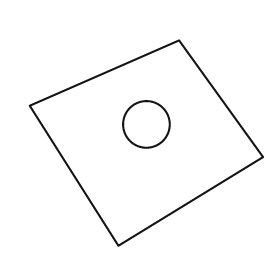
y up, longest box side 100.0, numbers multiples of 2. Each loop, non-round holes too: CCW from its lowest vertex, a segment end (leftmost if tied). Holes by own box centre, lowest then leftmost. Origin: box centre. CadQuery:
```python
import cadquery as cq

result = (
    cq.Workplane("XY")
    .moveTo(-12.0, -44.0)
    .lineTo(50.0, -6.0)
    .lineTo(14.0, 44.0)
    .lineTo(-50.0, 16.0)
    .close()
    .moveTo(0.0, 8.0)
    .circle(10.0)
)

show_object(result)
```